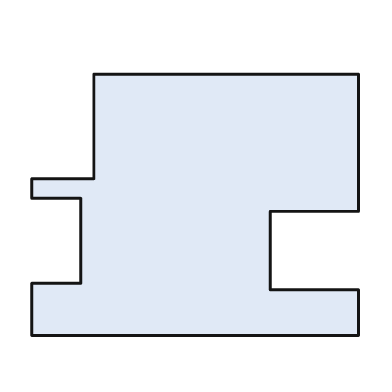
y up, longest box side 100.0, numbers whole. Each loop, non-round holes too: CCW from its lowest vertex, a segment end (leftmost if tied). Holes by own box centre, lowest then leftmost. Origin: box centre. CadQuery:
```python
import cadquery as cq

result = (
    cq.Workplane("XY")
    .moveTo(-50.0, -40.0)
    .lineTo(50.0, -40.0)
    .lineTo(50.0, -26.0)
    .lineTo(23.0, -26.0)
    .lineTo(23.0, -2.0)
    .lineTo(50.0, -2.0)
    .lineTo(50.0, 40.0)
    .lineTo(-31.0, 40.0)
    .lineTo(-31.0, 8.0)
    .lineTo(-50.0, 8.0)
    .lineTo(-50.0, 2.0)
    .lineTo(-35.0, 2.0)
    .lineTo(-35.0, -24.0)
    .lineTo(-50.0, -24.0)
    .close()
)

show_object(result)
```